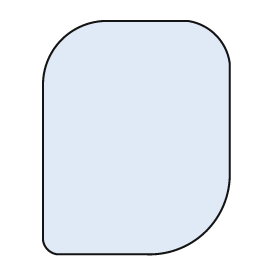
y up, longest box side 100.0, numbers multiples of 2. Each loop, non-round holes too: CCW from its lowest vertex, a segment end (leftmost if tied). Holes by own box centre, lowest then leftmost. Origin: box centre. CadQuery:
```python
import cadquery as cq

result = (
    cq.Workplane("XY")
    .moveTo(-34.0, -50.0)
    .lineTo(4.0, -50.0)
    .threePointArc((30.0, -40.0), (40.0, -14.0))
    .lineTo(40.0, 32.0)
    .threePointArc((34.0, 44.0), (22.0, 50.0))
    .lineTo(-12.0, 50.0)
    .threePointArc((-32.0, 42.0), (-40.0, 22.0))
    .lineTo(-40.0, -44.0)
    .threePointArc((-38.0, -48.0), (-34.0, -50.0))
    .close()
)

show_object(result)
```